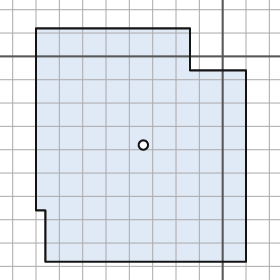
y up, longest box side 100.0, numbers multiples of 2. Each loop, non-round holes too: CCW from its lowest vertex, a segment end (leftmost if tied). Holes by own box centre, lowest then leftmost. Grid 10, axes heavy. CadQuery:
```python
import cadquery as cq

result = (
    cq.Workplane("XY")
    .moveTo(-76.0, -88.0)
    .lineTo(10.0, -88.0)
    .lineTo(10.0, -6.0)
    .lineTo(-14.0, -6.0)
    .lineTo(-14.0, 12.0)
    .lineTo(-80.0, 12.0)
    .lineTo(-80.0, -66.0)
    .lineTo(-76.0, -66.0)
    .close()
    .moveTo(-34.0, -38.0)
    .circle(2.0)
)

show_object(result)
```